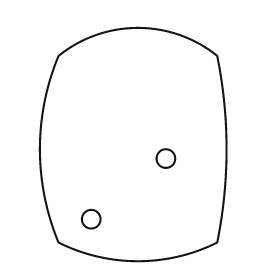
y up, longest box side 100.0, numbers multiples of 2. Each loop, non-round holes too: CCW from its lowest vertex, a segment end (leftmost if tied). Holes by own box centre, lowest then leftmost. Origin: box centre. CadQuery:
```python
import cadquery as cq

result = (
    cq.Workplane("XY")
    .moveTo(-32.0, -42.0)
    .threePointArc((2.0, -50.0), (36.0, -42.0))
    .threePointArc((40.0, -2.0), (36.0, 38.0))
    .threePointArc((2.0, 50.0), (-32.0, 38.0))
    .threePointArc((-40.0, -2.0), (-32.0, -42.0))
    .close()
    .moveTo(-18.0, -32.0)
    .circle(4.0)
    .moveTo(14.0, -6.0)
    .circle(4.0)
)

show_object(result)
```